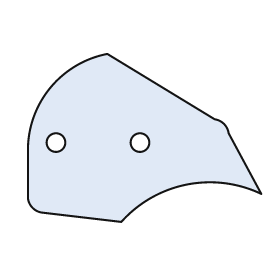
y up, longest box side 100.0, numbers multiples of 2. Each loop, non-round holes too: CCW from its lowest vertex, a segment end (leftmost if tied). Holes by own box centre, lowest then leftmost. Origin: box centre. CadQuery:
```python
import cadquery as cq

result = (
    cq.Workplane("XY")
    .moveTo(-10.0, -36.0)
    .threePointArc((18.0, -20.0), (50.0, -24.0))
    .lineTo(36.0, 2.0)
    .threePointArc((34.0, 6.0), (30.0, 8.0))
    .lineTo(-16.0, 36.0)
    .threePointArc((-40.0, 22.0), (-50.0, -4.0))
    .lineTo(-50.0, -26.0)
    .threePointArc((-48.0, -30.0), (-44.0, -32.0))
    .close()
    .moveTo(-38.0, -2.0)
    .circle(4.0)
    .moveTo(-2.0, -2.0)
    .circle(4.0)
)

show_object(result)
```